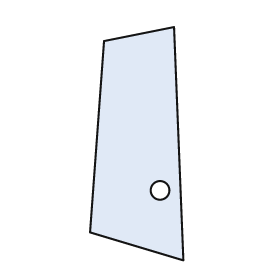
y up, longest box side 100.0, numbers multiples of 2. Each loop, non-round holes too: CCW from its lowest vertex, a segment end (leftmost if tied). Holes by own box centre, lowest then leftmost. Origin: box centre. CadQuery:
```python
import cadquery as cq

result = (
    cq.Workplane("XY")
    .moveTo(20.0, -50.0)
    .lineTo(16.0, 50.0)
    .lineTo(-14.0, 44.0)
    .lineTo(-20.0, -38.0)
    .close()
    .moveTo(10.0, -20.0)
    .circle(4.0)
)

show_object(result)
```